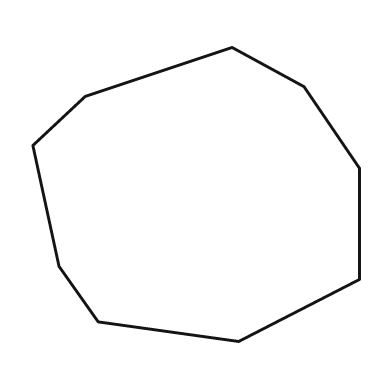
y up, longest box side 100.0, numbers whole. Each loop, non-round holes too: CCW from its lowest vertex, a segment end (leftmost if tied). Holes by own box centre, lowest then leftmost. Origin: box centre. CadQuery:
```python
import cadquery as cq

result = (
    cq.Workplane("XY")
    .moveTo(13.0, -45.0)
    .lineTo(50.0, -26.0)
    .lineTo(50.0, 8.0)
    .lineTo(33.0, 33.0)
    .lineTo(11.0, 45.0)
    .lineTo(-34.0, 30.0)
    .lineTo(-50.0, 15.0)
    .lineTo(-42.0, -22.0)
    .lineTo(-30.0, -39.0)
    .close()
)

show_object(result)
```